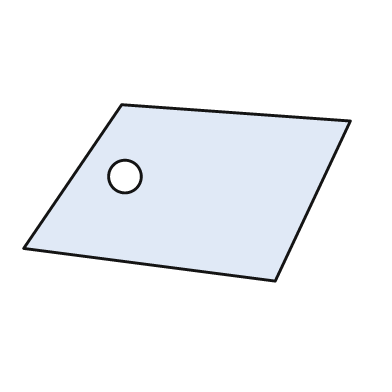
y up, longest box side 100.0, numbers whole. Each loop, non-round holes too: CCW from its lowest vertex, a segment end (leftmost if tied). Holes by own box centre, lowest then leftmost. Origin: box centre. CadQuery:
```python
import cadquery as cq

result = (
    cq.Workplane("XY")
    .moveTo(27.0, -27.0)
    .lineTo(50.0, 22.0)
    .lineTo(-20.0, 27.0)
    .lineTo(-50.0, -17.0)
    .close()
    .moveTo(-19.0, 5.0)
    .circle(5.0)
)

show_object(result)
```